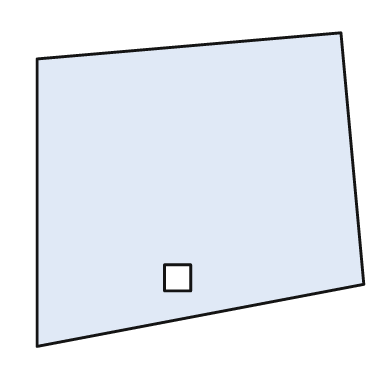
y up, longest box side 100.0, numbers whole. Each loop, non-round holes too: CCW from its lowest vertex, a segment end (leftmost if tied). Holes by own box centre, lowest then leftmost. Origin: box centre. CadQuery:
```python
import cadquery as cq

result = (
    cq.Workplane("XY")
    .moveTo(-50.0, -48.0)
    .lineTo(50.0, -29.0)
    .lineTo(43.0, 48.0)
    .lineTo(-50.0, 40.0)
    .close()
    .moveTo(-11.0, -31.0)
    .lineTo(-3.0, -31.0)
    .lineTo(-3.0, -23.0)
    .lineTo(-11.0, -23.0)
    .close()
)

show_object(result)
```